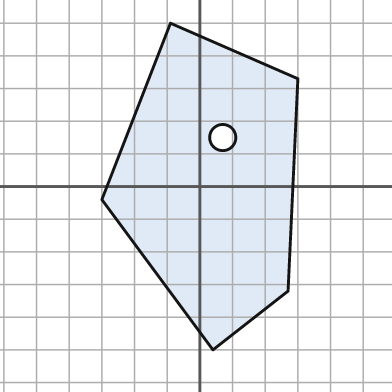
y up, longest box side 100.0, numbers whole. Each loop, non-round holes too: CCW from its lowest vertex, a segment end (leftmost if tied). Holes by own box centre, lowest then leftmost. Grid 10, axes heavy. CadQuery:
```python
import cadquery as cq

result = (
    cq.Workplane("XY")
    .moveTo(4.0, -50.0)
    .lineTo(27.0, -32.0)
    .lineTo(30.0, 33.0)
    .lineTo(-9.0, 50.0)
    .lineTo(-30.0, -4.0)
    .close()
    .moveTo(7.0, 15.0)
    .circle(4.0)
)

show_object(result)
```